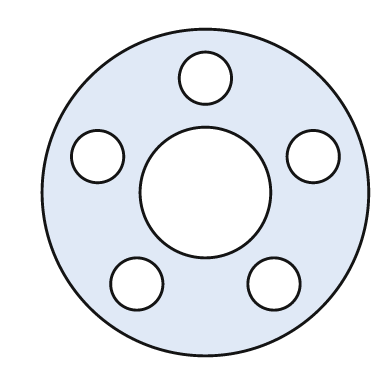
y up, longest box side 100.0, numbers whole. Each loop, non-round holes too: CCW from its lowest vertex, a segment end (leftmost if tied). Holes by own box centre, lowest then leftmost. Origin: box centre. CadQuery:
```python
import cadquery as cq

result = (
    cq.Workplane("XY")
    .moveTo(0.0, 0.0)
    .circle(50.0)
    .moveTo(-21.0, -28.0)
    .circle(8.0)
    .moveTo(21.0, -28.0)
    .circle(8.0)
    .moveTo(0.0, 0.0)
    .circle(20.0)
    .moveTo(-33.0, 11.0)
    .circle(8.0)
    .moveTo(33.0, 11.0)
    .circle(8.0)
    .moveTo(0.0, 35.0)
    .circle(8.0)
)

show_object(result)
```